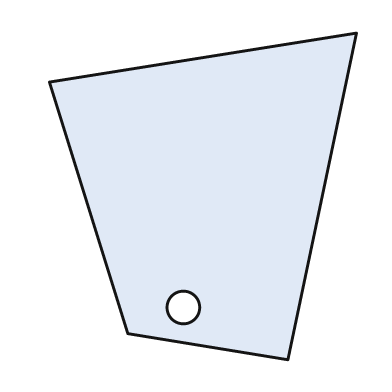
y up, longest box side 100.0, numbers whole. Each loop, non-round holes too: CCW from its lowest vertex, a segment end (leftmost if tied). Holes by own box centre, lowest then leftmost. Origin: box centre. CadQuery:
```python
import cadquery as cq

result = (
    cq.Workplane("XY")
    .moveTo(26.0, -50.0)
    .lineTo(47.0, 50.0)
    .lineTo(-47.0, 35.0)
    .lineTo(-23.0, -42.0)
    .close()
    .moveTo(-6.0, -34.0)
    .circle(5.0)
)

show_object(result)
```